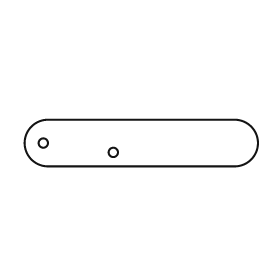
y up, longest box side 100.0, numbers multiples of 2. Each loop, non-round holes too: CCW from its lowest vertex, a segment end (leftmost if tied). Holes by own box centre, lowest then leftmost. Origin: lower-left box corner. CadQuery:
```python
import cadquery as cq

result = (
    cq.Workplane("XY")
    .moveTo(10.0, 0.0)
    .lineTo(90.0, 0.0)
    .threePointArc((100.0, 10.0), (90.0, 20.0))
    .lineTo(10.0, 20.0)
    .threePointArc((0.0, 10.0), (10.0, 0.0))
    .close()
    .moveTo(38.0, 6.0)
    .circle(2.0)
    .moveTo(8.0, 10.0)
    .circle(2.0)
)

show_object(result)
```